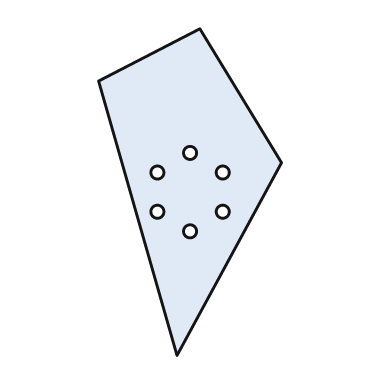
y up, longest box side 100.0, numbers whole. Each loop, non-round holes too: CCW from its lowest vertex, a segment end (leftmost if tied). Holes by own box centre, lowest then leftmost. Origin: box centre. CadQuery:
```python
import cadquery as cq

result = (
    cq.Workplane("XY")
    .moveTo(-4.0, -50.0)
    .lineTo(28.0, 9.0)
    .lineTo(3.0, 50.0)
    .lineTo(-28.0, 34.0)
    .close()
    .moveTo(0.0, -12.0)
    .circle(2.0)
    .moveTo(-10.0, -6.0)
    .circle(2.0)
    .moveTo(10.0, -6.0)
    .circle(2.0)
    .moveTo(-10.0, 6.0)
    .circle(2.0)
    .moveTo(10.0, 6.0)
    .circle(2.0)
    .moveTo(0.0, 12.0)
    .circle(2.0)
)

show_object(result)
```